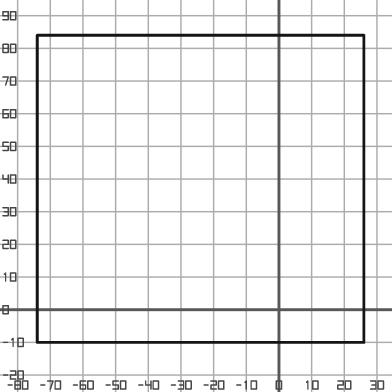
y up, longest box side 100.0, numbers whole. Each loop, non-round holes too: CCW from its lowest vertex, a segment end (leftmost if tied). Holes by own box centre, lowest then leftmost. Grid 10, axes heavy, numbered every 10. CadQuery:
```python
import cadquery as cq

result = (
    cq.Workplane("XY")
    .moveTo(-74.0, -10.0)
    .lineTo(26.0, -10.0)
    .lineTo(26.0, 84.0)
    .lineTo(-74.0, 84.0)
    .close()
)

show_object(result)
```